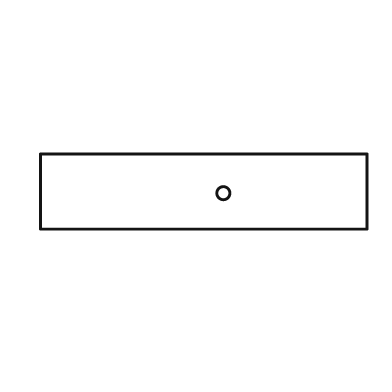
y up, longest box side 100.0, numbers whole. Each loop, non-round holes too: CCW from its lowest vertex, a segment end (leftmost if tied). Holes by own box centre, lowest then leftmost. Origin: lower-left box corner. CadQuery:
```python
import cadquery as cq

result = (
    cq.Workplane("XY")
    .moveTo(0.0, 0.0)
    .lineTo(100.0, 0.0)
    .lineTo(100.0, 23.0)
    .lineTo(0.0, 23.0)
    .close()
    .moveTo(56.0, 11.0)
    .circle(2.0)
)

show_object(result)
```